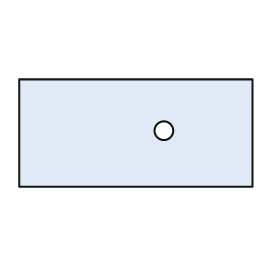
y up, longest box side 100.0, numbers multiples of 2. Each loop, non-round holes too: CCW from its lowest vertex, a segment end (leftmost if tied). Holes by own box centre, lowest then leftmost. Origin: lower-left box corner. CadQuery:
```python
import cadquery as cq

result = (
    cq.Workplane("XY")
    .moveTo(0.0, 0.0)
    .lineTo(100.0, 0.0)
    .lineTo(100.0, 46.0)
    .lineTo(0.0, 46.0)
    .close()
    .moveTo(62.0, 24.0)
    .circle(4.0)
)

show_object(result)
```